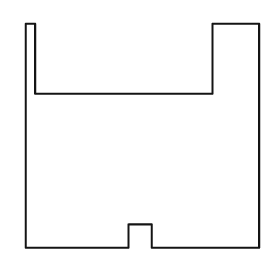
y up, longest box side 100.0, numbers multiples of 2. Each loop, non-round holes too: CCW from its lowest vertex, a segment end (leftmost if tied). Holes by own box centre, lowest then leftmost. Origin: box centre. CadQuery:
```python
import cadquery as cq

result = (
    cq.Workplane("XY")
    .moveTo(-50.0, -48.0)
    .lineTo(-6.0, -48.0)
    .lineTo(-6.0, -38.0)
    .lineTo(4.0, -38.0)
    .lineTo(4.0, -48.0)
    .lineTo(50.0, -48.0)
    .lineTo(50.0, 48.0)
    .lineTo(30.0, 48.0)
    .lineTo(30.0, 18.0)
    .lineTo(-46.0, 18.0)
    .lineTo(-46.0, 48.0)
    .lineTo(-50.0, 48.0)
    .close()
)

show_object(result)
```